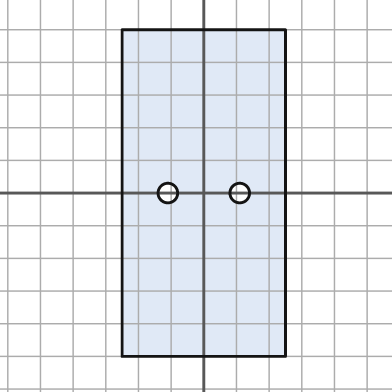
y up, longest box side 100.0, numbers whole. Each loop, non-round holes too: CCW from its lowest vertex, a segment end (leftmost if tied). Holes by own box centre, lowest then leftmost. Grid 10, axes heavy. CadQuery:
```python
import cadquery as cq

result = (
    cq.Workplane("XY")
    .moveTo(-25.0, -50.0)
    .lineTo(25.0, -50.0)
    .lineTo(25.0, 50.0)
    .lineTo(-25.0, 50.0)
    .close()
    .moveTo(-11.0, 0.0)
    .circle(3.0)
    .moveTo(11.0, 0.0)
    .circle(3.0)
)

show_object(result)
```